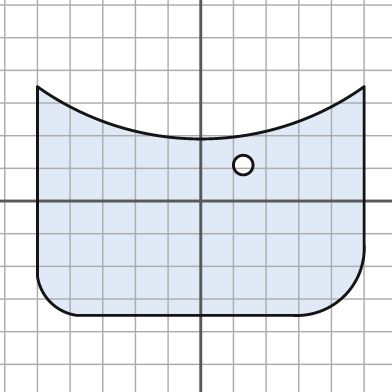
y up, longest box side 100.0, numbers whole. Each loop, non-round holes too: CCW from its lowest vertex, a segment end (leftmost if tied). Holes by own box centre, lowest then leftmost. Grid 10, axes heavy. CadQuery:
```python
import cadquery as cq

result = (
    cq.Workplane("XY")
    .moveTo(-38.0, -35.0)
    .lineTo(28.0, -35.0)
    .threePointArc((44.0, -29.0), (50.0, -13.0))
    .lineTo(50.0, 35.0)
    .threePointArc((0.0, 19.0), (-50.0, 35.0))
    .lineTo(-50.0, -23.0)
    .threePointArc((-46.0, -31.0), (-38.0, -35.0))
    .close()
    .moveTo(13.0, 11.0)
    .circle(3.0)
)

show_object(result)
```